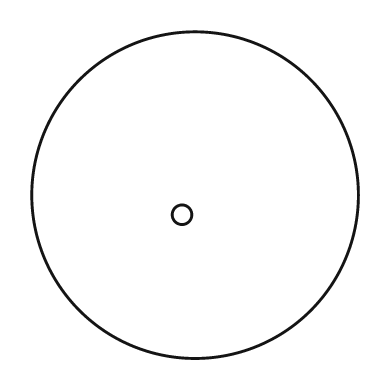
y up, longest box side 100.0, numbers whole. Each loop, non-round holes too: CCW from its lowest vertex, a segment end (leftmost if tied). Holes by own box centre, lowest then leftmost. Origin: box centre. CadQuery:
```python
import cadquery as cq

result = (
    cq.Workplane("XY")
    .moveTo(0.0, 0.0)
    .circle(50.0)
    .moveTo(-4.0, -6.0)
    .circle(3.0)
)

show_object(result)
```